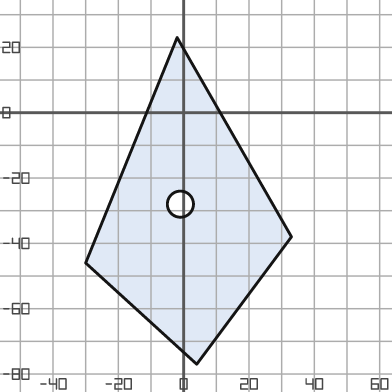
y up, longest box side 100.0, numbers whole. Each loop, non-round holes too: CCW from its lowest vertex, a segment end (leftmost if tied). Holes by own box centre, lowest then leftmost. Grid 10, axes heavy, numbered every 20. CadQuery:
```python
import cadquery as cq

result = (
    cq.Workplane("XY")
    .moveTo(4.0, -77.0)
    .lineTo(33.0, -38.0)
    .lineTo(-2.0, 23.0)
    .lineTo(-30.0, -46.0)
    .close()
    .moveTo(-1.0, -28.0)
    .circle(4.0)
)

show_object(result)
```